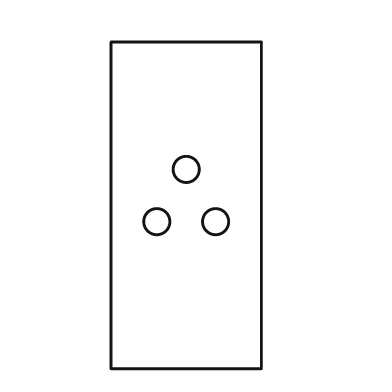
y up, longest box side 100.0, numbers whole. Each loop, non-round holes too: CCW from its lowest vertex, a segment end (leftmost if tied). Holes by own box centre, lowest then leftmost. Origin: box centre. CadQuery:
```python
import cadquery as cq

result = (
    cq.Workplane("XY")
    .moveTo(-23.0, -50.0)
    .lineTo(23.0, -50.0)
    .lineTo(23.0, 50.0)
    .lineTo(-23.0, 50.0)
    .close()
    .moveTo(-9.0, -5.0)
    .circle(4.0)
    .moveTo(9.0, -5.0)
    .circle(4.0)
    .moveTo(0.0, 11.0)
    .circle(4.0)
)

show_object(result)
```